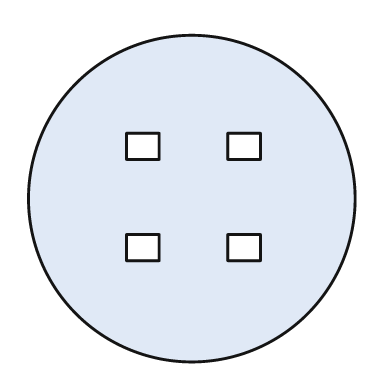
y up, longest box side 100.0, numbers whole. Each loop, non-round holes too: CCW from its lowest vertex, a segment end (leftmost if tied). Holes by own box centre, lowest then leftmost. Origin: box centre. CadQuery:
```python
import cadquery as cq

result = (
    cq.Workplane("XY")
    .moveTo(0.0, 0.0)
    .circle(50.0)
    .moveTo(-20.0, -19.0)
    .lineTo(-10.0, -19.0)
    .lineTo(-10.0, -11.0)
    .lineTo(-20.0, -11.0)
    .close()
    .moveTo(11.0, -19.0)
    .lineTo(21.0, -19.0)
    .lineTo(21.0, -11.0)
    .lineTo(11.0, -11.0)
    .close()
    .moveTo(-20.0, 12.0)
    .lineTo(-10.0, 12.0)
    .lineTo(-10.0, 20.0)
    .lineTo(-20.0, 20.0)
    .close()
    .moveTo(11.0, 12.0)
    .lineTo(21.0, 12.0)
    .lineTo(21.0, 20.0)
    .lineTo(11.0, 20.0)
    .close()
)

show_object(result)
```